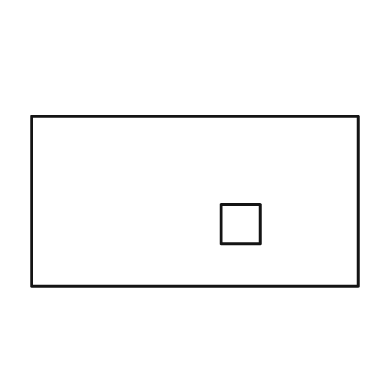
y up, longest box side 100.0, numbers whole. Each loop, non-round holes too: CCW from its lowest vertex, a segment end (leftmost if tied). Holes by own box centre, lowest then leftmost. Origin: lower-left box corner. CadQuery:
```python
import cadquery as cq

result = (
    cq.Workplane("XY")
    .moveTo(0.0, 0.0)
    .lineTo(100.0, 0.0)
    .lineTo(100.0, 52.0)
    .lineTo(0.0, 52.0)
    .close()
    .moveTo(58.0, 13.0)
    .lineTo(70.0, 13.0)
    .lineTo(70.0, 25.0)
    .lineTo(58.0, 25.0)
    .close()
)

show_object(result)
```